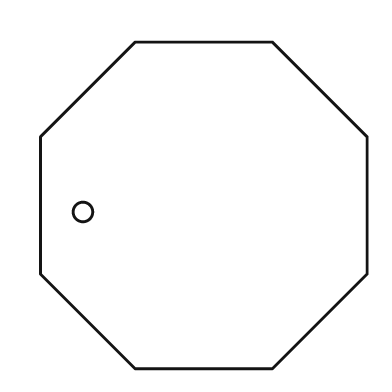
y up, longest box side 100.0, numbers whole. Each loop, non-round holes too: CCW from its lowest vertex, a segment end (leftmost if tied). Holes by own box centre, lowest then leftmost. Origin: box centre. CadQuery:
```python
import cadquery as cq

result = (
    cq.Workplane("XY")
    .moveTo(-21.0, -50.0)
    .lineTo(21.0, -50.0)
    .lineTo(50.0, -21.0)
    .lineTo(50.0, 21.0)
    .lineTo(21.0, 50.0)
    .lineTo(-21.0, 50.0)
    .lineTo(-50.0, 21.0)
    .lineTo(-50.0, -21.0)
    .close()
    .moveTo(-37.0, -2.0)
    .circle(3.0)
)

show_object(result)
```